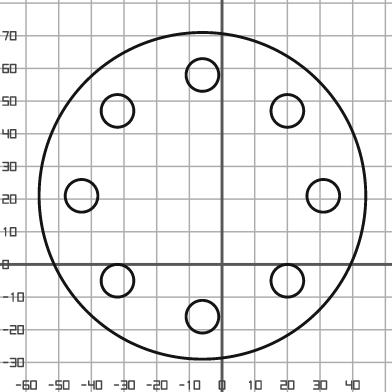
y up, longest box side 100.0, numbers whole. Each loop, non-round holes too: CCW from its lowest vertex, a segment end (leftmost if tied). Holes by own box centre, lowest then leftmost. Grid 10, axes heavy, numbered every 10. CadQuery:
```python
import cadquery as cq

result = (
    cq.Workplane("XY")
    .moveTo(-6.0, 21.0)
    .circle(50.0)
    .moveTo(-6.0, -16.0)
    .circle(5.0)
    .moveTo(-32.0, -5.0)
    .circle(5.0)
    .moveTo(20.0, -5.0)
    .circle(5.0)
    .moveTo(-43.0, 21.0)
    .circle(5.0)
    .moveTo(31.0, 21.0)
    .circle(5.0)
    .moveTo(-32.0, 47.0)
    .circle(5.0)
    .moveTo(20.0, 47.0)
    .circle(5.0)
    .moveTo(-6.0, 58.0)
    .circle(5.0)
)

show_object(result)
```